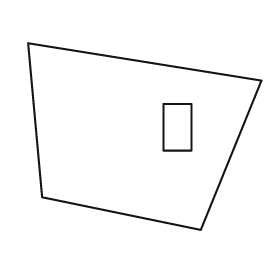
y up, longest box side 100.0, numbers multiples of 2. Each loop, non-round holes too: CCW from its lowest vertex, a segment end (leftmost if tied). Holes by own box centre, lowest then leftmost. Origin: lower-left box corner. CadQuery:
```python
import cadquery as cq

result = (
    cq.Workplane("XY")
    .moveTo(74.0, 0.0)
    .lineTo(100.0, 64.0)
    .lineTo(0.0, 80.0)
    .lineTo(6.0, 14.0)
    .close()
    .moveTo(58.0, 34.0)
    .lineTo(70.0, 34.0)
    .lineTo(70.0, 54.0)
    .lineTo(58.0, 54.0)
    .close()
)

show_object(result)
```